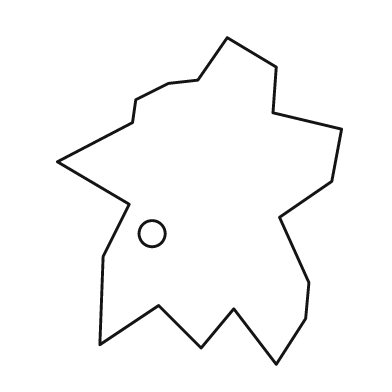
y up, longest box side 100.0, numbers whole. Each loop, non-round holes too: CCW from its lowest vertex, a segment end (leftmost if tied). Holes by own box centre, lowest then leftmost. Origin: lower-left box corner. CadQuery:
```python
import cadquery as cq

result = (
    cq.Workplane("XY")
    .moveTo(67.0, 0.0)
    .lineTo(76.0, 14.0)
    .lineTo(77.0, 25.0)
    .lineTo(68.0, 45.0)
    .lineTo(84.0, 56.0)
    .lineTo(87.0, 72.0)
    .lineTo(66.0, 77.0)
    .lineTo(67.0, 91.0)
    .lineTo(52.0, 100.0)
    .lineTo(43.0, 87.0)
    .lineTo(34.0, 86.0)
    .lineTo(24.0, 81.0)
    .lineTo(23.0, 74.0)
    .lineTo(0.0, 62.0)
    .lineTo(22.0, 49.0)
    .lineTo(14.0, 33.0)
    .lineTo(13.0, 6.0)
    .lineTo(31.0, 18.0)
    .lineTo(44.0, 5.0)
    .lineTo(54.0, 17.0)
    .close()
    .moveTo(29.0, 40.0)
    .circle(4.0)
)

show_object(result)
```